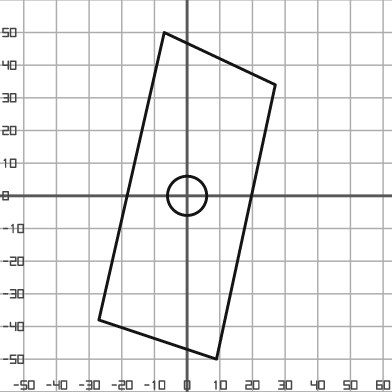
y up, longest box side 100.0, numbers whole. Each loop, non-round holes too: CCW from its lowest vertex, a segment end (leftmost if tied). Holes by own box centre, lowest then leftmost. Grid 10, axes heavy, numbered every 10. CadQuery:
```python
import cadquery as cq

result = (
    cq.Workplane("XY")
    .moveTo(9.0, -50.0)
    .lineTo(27.0, 34.0)
    .lineTo(-7.0, 50.0)
    .lineTo(-27.0, -38.0)
    .close()
    .moveTo(0.0, 0.0)
    .circle(6.0)
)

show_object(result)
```